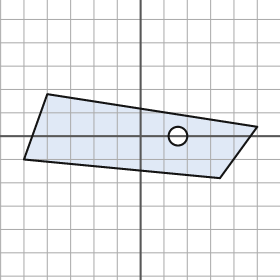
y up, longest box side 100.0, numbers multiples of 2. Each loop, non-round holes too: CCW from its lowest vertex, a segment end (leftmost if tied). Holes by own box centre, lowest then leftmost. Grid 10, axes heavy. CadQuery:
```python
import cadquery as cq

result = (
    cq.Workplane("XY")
    .moveTo(34.0, -18.0)
    .lineTo(50.0, 4.0)
    .lineTo(-40.0, 18.0)
    .lineTo(-50.0, -10.0)
    .close()
    .moveTo(16.0, 0.0)
    .circle(4.0)
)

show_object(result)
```